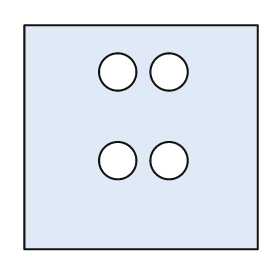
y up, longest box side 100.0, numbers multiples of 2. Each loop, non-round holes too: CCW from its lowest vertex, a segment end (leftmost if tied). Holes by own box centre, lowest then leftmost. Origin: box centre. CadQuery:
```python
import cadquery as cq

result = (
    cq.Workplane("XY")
    .moveTo(-50.0, -48.0)
    .lineTo(50.0, -48.0)
    .lineTo(50.0, 48.0)
    .lineTo(-50.0, 48.0)
    .close()
    .moveTo(-10.0, -10.0)
    .circle(8.0)
    .moveTo(12.0, -10.0)
    .circle(8.0)
    .moveTo(-10.0, 28.0)
    .circle(8.0)
    .moveTo(12.0, 28.0)
    .circle(8.0)
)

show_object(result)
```